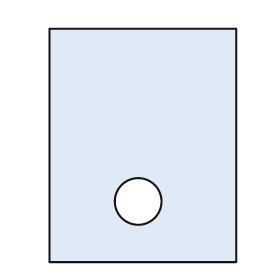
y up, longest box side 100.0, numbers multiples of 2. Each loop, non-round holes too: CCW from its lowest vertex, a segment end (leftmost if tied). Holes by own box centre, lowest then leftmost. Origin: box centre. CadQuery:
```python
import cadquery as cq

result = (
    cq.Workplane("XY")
    .moveTo(-40.0, -50.0)
    .lineTo(40.0, -50.0)
    .lineTo(40.0, 50.0)
    .lineTo(-40.0, 50.0)
    .close()
    .moveTo(-2.0, -24.0)
    .circle(10.0)
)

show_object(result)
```